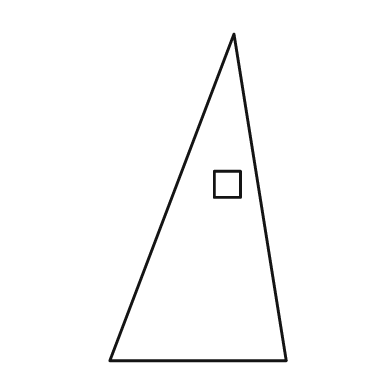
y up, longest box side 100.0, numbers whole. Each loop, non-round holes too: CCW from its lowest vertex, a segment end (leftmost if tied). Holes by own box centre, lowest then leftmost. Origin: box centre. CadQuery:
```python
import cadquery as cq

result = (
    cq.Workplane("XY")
    .moveTo(-27.0, -50.0)
    .lineTo(27.0, -50.0)
    .lineTo(11.0, 50.0)
    .close()
    .moveTo(5.0, 0.0)
    .lineTo(13.0, 0.0)
    .lineTo(13.0, 8.0)
    .lineTo(5.0, 8.0)
    .close()
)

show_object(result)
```